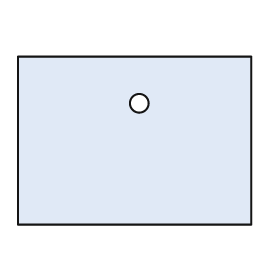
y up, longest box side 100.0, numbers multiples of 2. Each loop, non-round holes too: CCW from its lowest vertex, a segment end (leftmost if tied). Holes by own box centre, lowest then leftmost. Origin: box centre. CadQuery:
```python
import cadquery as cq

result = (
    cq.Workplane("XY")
    .moveTo(-50.0, -36.0)
    .lineTo(50.0, -36.0)
    .lineTo(50.0, 36.0)
    .lineTo(-50.0, 36.0)
    .close()
    .moveTo(2.0, 16.0)
    .circle(4.0)
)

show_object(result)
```